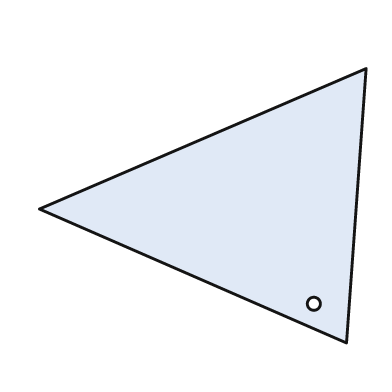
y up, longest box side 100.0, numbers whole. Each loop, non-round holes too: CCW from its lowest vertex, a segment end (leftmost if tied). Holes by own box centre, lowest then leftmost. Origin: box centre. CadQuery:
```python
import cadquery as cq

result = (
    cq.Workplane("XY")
    .moveTo(44.0, -42.0)
    .lineTo(50.0, 42.0)
    .lineTo(-50.0, -1.0)
    .close()
    .moveTo(34.0, -30.0)
    .circle(2.0)
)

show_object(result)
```